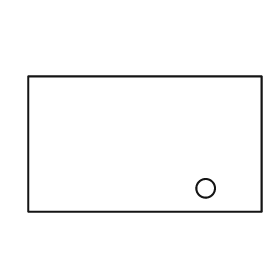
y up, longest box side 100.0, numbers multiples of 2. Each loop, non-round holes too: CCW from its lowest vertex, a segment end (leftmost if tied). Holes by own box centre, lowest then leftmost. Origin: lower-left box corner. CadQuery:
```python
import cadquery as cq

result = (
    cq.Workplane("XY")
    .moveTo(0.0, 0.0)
    .lineTo(100.0, 0.0)
    .lineTo(100.0, 58.0)
    .lineTo(0.0, 58.0)
    .close()
    .moveTo(76.0, 10.0)
    .circle(4.0)
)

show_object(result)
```